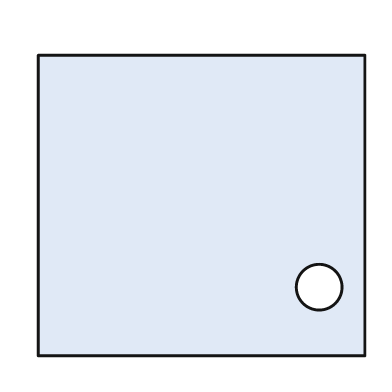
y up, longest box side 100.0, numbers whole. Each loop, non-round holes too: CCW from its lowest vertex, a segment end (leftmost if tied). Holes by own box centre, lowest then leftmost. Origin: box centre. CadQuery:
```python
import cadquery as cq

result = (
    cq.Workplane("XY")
    .moveTo(-50.0, -46.0)
    .lineTo(50.0, -46.0)
    .lineTo(50.0, 46.0)
    .lineTo(-50.0, 46.0)
    .close()
    .moveTo(36.0, -25.0)
    .circle(7.0)
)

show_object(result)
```